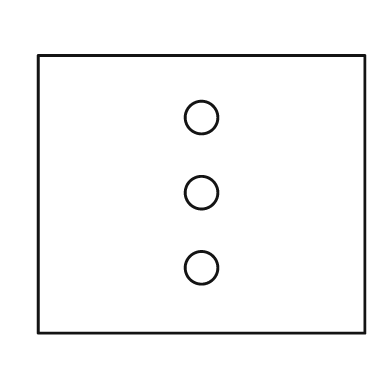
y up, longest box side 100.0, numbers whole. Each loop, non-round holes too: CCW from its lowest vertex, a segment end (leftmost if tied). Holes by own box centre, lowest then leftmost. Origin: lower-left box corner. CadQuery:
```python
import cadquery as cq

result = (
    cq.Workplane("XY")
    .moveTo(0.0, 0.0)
    .lineTo(100.0, 0.0)
    .lineTo(100.0, 85.0)
    .lineTo(0.0, 85.0)
    .close()
    .moveTo(50.0, 20.0)
    .circle(5.0)
    .moveTo(50.0, 43.0)
    .circle(5.0)
    .moveTo(50.0, 66.0)
    .circle(5.0)
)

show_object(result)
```